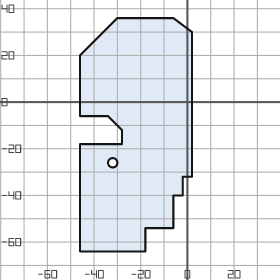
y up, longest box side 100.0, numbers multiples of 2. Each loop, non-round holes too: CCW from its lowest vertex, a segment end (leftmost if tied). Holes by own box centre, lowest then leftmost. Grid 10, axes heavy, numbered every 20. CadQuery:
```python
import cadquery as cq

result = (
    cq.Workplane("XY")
    .moveTo(-46.0, -64.0)
    .lineTo(-18.0, -64.0)
    .lineTo(-18.0, -54.0)
    .lineTo(-6.0, -54.0)
    .lineTo(-6.0, -40.0)
    .lineTo(-2.0, -40.0)
    .lineTo(-2.0, -32.0)
    .lineTo(2.0, -32.0)
    .lineTo(2.0, 30.0)
    .lineTo(-6.0, 36.0)
    .lineTo(-30.0, 36.0)
    .lineTo(-46.0, 20.0)
    .lineTo(-46.0, -6.0)
    .lineTo(-34.0, -6.0)
    .lineTo(-28.0, -12.0)
    .lineTo(-28.0, -18.0)
    .lineTo(-46.0, -18.0)
    .close()
    .moveTo(-32.0, -26.0)
    .circle(2.0)
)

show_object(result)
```